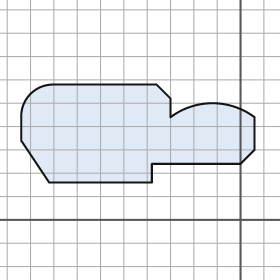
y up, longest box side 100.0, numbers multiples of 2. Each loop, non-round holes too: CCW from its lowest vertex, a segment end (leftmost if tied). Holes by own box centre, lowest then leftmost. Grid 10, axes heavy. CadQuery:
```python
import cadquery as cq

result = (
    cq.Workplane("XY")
    .moveTo(-82.0, 16.0)
    .lineTo(-38.0, 16.0)
    .lineTo(-38.0, 24.0)
    .lineTo(0.0, 24.0)
    .lineTo(6.0, 30.0)
    .lineTo(6.0, 44.0)
    .threePointArc((-12.0, 50.0), (-30.0, 44.0))
    .lineTo(-30.0, 52.0)
    .lineTo(-36.0, 58.0)
    .lineTo(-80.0, 58.0)
    .threePointArc((-90.0, 54.0), (-94.0, 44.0))
    .lineTo(-94.0, 34.0)
    .close()
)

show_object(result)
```